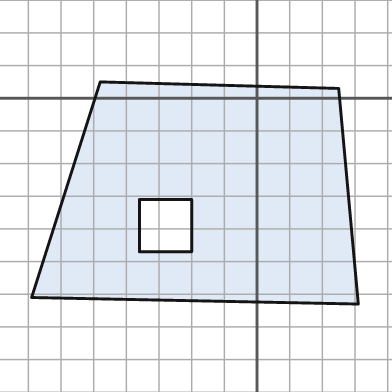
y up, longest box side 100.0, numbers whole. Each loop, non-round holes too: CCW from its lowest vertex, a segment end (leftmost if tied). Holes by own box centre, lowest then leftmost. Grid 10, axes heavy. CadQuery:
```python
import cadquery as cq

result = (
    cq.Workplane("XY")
    .moveTo(31.0, -63.0)
    .lineTo(25.0, 3.0)
    .lineTo(-48.0, 5.0)
    .lineTo(-69.0, -61.0)
    .close()
    .moveTo(-36.0, -47.0)
    .lineTo(-20.0, -47.0)
    .lineTo(-20.0, -31.0)
    .lineTo(-36.0, -31.0)
    .close()
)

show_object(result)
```